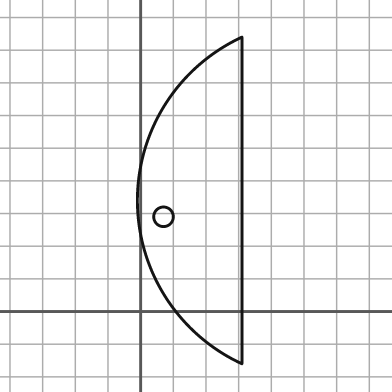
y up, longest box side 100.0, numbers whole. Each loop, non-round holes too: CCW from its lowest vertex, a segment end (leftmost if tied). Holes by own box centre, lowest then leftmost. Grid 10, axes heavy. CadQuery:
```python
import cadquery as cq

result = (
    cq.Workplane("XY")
    .moveTo(31.0, -16.0)
    .lineTo(31.0, 84.0)
    .threePointArc((-1.0, 34.0), (31.0, -16.0))
    .close()
    .moveTo(7.0, 29.0)
    .circle(3.0)
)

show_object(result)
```